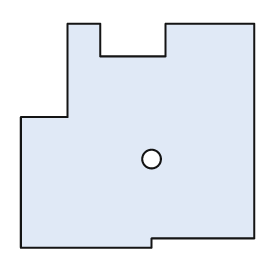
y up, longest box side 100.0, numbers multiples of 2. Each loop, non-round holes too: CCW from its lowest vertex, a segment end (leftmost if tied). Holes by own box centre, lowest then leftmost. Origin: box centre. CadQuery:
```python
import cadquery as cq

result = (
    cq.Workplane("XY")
    .moveTo(-50.0, -48.0)
    .lineTo(6.0, -48.0)
    .lineTo(6.0, -44.0)
    .lineTo(50.0, -44.0)
    .lineTo(50.0, 48.0)
    .lineTo(12.0, 48.0)
    .lineTo(12.0, 34.0)
    .lineTo(-16.0, 34.0)
    .lineTo(-16.0, 48.0)
    .lineTo(-30.0, 48.0)
    .lineTo(-30.0, 8.0)
    .lineTo(-50.0, 8.0)
    .close()
    .moveTo(6.0, -10.0)
    .circle(4.0)
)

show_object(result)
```